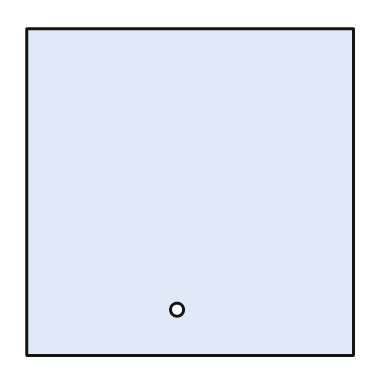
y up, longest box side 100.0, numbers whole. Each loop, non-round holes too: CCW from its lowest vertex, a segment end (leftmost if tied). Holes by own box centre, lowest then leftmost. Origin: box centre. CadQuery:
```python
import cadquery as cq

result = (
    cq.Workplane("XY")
    .moveTo(-50.0, -50.0)
    .lineTo(50.0, -50.0)
    .lineTo(50.0, 50.0)
    .lineTo(-50.0, 50.0)
    .close()
    .moveTo(-4.0, -36.0)
    .circle(2.0)
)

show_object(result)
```